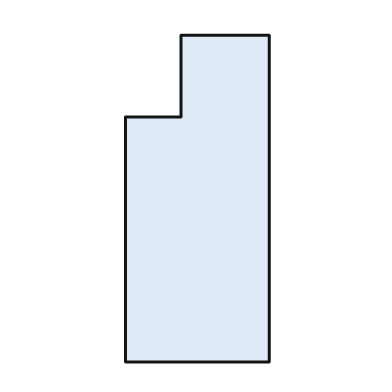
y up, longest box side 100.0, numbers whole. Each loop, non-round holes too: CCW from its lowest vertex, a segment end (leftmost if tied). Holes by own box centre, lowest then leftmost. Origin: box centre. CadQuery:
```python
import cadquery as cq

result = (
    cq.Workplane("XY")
    .moveTo(-22.0, -50.0)
    .lineTo(22.0, -50.0)
    .lineTo(22.0, 50.0)
    .lineTo(-5.0, 50.0)
    .lineTo(-5.0, 25.0)
    .lineTo(-22.0, 25.0)
    .close()
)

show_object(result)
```